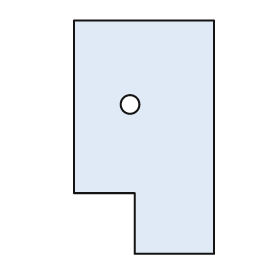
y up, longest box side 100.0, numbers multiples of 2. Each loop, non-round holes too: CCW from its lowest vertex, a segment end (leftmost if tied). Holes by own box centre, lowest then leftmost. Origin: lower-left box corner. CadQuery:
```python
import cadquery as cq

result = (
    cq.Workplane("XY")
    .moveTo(26.0, 0.0)
    .lineTo(60.0, 0.0)
    .lineTo(60.0, 100.0)
    .lineTo(0.0, 100.0)
    .lineTo(0.0, 26.0)
    .lineTo(26.0, 26.0)
    .close()
    .moveTo(24.0, 64.0)
    .circle(4.0)
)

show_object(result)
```